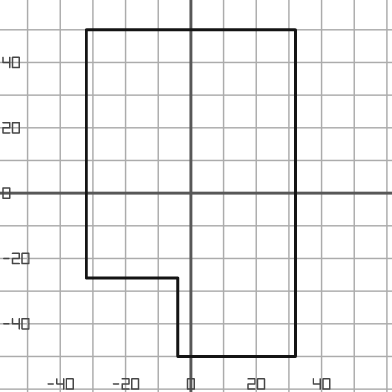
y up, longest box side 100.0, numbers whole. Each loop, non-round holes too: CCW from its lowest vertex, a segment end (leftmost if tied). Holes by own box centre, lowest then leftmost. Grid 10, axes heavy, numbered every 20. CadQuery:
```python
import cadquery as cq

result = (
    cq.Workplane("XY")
    .moveTo(-4.0, -50.0)
    .lineTo(32.0, -50.0)
    .lineTo(32.0, 50.0)
    .lineTo(-32.0, 50.0)
    .lineTo(-32.0, -26.0)
    .lineTo(-4.0, -26.0)
    .close()
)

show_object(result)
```